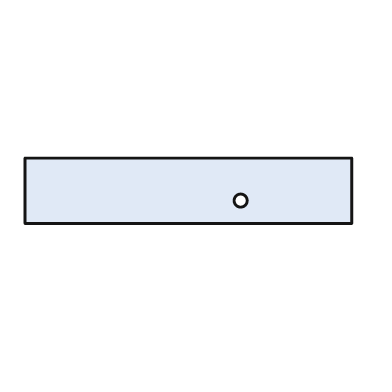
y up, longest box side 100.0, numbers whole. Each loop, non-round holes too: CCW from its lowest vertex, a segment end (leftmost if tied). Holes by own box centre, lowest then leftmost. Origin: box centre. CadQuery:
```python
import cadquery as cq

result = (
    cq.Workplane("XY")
    .moveTo(-50.0, -10.0)
    .lineTo(50.0, -10.0)
    .lineTo(50.0, 10.0)
    .lineTo(-50.0, 10.0)
    .close()
    .moveTo(16.0, -3.0)
    .circle(2.0)
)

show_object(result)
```